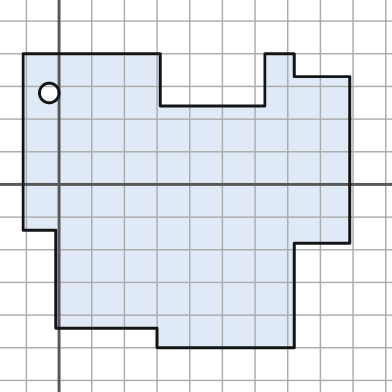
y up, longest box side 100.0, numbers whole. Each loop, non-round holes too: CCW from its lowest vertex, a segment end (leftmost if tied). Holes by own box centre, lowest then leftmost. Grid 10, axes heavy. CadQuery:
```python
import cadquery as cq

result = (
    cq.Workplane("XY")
    .moveTo(30.0, -50.0)
    .lineTo(72.0, -50.0)
    .lineTo(72.0, -18.0)
    .lineTo(89.0, -18.0)
    .lineTo(89.0, 33.0)
    .lineTo(72.0, 33.0)
    .lineTo(72.0, 40.0)
    .lineTo(63.0, 40.0)
    .lineTo(63.0, 24.0)
    .lineTo(31.0, 24.0)
    .lineTo(31.0, 40.0)
    .lineTo(-11.0, 40.0)
    .lineTo(-11.0, -14.0)
    .lineTo(-1.0, -14.0)
    .lineTo(-1.0, -44.0)
    .lineTo(30.0, -44.0)
    .close()
    .moveTo(-3.0, 28.0)
    .circle(3.0)
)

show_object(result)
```